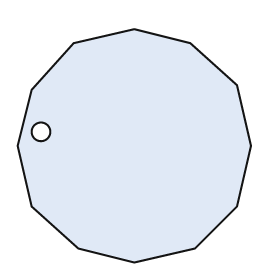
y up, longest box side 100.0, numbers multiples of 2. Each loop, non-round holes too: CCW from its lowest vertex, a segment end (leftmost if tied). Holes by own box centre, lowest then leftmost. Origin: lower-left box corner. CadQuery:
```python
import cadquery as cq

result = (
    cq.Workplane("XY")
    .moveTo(50.0, 0.0)
    .lineTo(76.0, 6.0)
    .lineTo(94.0, 24.0)
    .lineTo(100.0, 50.0)
    .lineTo(94.0, 76.0)
    .lineTo(74.0, 94.0)
    .lineTo(50.0, 100.0)
    .lineTo(24.0, 94.0)
    .lineTo(6.0, 74.0)
    .lineTo(0.0, 50.0)
    .lineTo(6.0, 24.0)
    .lineTo(26.0, 6.0)
    .close()
    .moveTo(10.0, 56.0)
    .circle(4.0)
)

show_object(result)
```